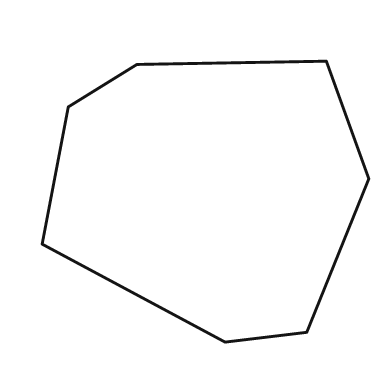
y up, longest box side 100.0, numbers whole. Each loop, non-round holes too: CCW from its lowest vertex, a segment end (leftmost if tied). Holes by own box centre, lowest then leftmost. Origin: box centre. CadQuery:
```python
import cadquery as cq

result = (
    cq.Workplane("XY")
    .moveTo(6.0, -43.0)
    .lineTo(31.0, -40.0)
    .lineTo(50.0, 7.0)
    .lineTo(37.0, 43.0)
    .lineTo(-21.0, 42.0)
    .lineTo(-42.0, 29.0)
    .lineTo(-50.0, -13.0)
    .close()
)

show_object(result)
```